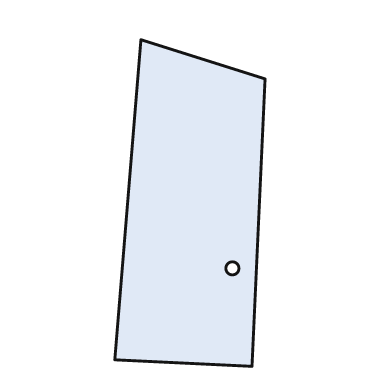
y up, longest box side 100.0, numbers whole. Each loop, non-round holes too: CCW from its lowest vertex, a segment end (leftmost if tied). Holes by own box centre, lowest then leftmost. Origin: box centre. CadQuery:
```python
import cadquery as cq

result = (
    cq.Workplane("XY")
    .moveTo(19.0, -50.0)
    .lineTo(23.0, 38.0)
    .lineTo(-15.0, 50.0)
    .lineTo(-23.0, -48.0)
    .close()
    .moveTo(13.0, -20.0)
    .circle(2.0)
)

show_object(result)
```